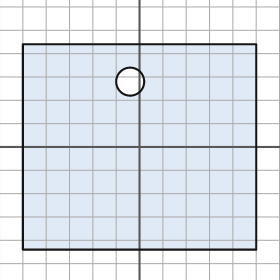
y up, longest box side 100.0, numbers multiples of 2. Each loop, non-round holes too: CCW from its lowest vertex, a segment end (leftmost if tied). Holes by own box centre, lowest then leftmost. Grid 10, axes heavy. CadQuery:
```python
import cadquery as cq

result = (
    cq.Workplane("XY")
    .moveTo(-50.0, -44.0)
    .lineTo(50.0, -44.0)
    .lineTo(50.0, 44.0)
    .lineTo(-50.0, 44.0)
    .close()
    .moveTo(-4.0, 28.0)
    .circle(6.0)
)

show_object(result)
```